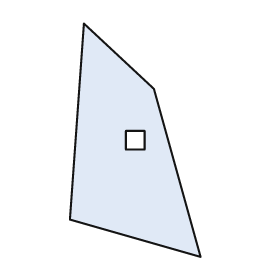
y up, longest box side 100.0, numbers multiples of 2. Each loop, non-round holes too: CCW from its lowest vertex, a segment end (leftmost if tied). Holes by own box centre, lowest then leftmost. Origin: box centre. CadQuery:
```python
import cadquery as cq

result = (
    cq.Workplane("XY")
    .moveTo(28.0, -50.0)
    .lineTo(8.0, 22.0)
    .lineTo(-22.0, 50.0)
    .lineTo(-28.0, -34.0)
    .close()
    .moveTo(-4.0, -4.0)
    .lineTo(4.0, -4.0)
    .lineTo(4.0, 4.0)
    .lineTo(-4.0, 4.0)
    .close()
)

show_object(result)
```